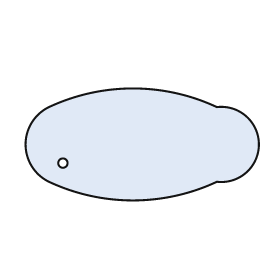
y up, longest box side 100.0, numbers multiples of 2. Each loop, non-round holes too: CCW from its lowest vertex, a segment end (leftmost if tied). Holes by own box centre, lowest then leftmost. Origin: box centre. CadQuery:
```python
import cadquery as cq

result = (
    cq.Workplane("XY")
    .moveTo(-40.0, -16.0)
    .threePointArc((-4.0, -24.0), (32.0, -16.0))
    .threePointArc((50.0, 0.0), (32.0, 16.0))
    .threePointArc((-4.0, 24.0), (-40.0, 16.0))
    .threePointArc((-50.0, 0.0), (-40.0, -16.0))
    .close()
    .moveTo(-34.0, -8.0)
    .circle(2.0)
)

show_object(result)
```